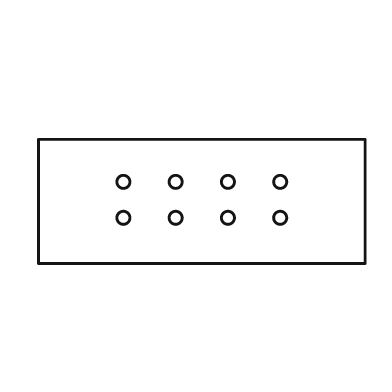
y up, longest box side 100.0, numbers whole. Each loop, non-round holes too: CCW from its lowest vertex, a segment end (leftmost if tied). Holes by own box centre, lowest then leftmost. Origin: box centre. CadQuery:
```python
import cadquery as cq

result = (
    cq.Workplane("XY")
    .moveTo(-50.0, -19.0)
    .lineTo(50.0, -19.0)
    .lineTo(50.0, 19.0)
    .lineTo(-50.0, 19.0)
    .close()
    .moveTo(-24.0, -5.0)
    .circle(2.0)
    .moveTo(-8.0, -5.0)
    .circle(2.0)
    .moveTo(8.0, -5.0)
    .circle(2.0)
    .moveTo(24.0, -5.0)
    .circle(2.0)
    .moveTo(-24.0, 6.0)
    .circle(2.0)
    .moveTo(-8.0, 6.0)
    .circle(2.0)
    .moveTo(8.0, 6.0)
    .circle(2.0)
    .moveTo(24.0, 6.0)
    .circle(2.0)
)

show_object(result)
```